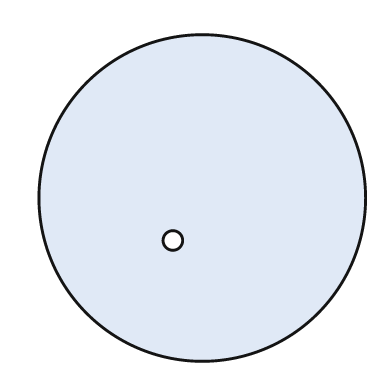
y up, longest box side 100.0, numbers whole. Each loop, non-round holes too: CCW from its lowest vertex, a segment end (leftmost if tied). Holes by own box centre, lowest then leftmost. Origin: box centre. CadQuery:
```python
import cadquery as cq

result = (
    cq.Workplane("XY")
    .moveTo(0.0, 0.0)
    .circle(50.0)
    .moveTo(-9.0, -13.0)
    .circle(3.0)
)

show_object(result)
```